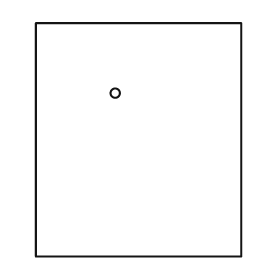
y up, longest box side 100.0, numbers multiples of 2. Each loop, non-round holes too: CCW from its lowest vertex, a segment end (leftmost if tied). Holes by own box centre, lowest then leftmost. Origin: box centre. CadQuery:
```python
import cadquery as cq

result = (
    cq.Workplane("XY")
    .moveTo(-44.0, -50.0)
    .lineTo(44.0, -50.0)
    .lineTo(44.0, 50.0)
    .lineTo(-44.0, 50.0)
    .close()
    .moveTo(-10.0, 20.0)
    .circle(2.0)
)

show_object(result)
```